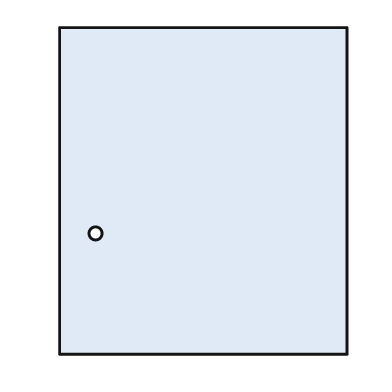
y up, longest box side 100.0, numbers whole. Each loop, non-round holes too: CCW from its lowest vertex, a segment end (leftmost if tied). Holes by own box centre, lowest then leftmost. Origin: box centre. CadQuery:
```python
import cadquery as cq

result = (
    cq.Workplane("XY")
    .moveTo(-44.0, -50.0)
    .lineTo(44.0, -50.0)
    .lineTo(44.0, 50.0)
    .lineTo(-44.0, 50.0)
    .close()
    .moveTo(-33.0, -13.0)
    .circle(2.0)
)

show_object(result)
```